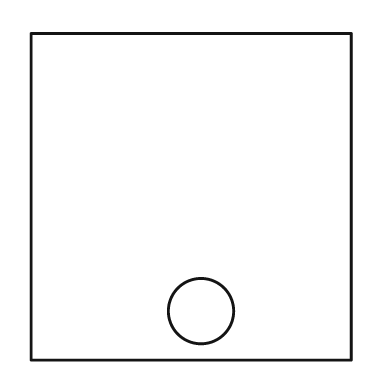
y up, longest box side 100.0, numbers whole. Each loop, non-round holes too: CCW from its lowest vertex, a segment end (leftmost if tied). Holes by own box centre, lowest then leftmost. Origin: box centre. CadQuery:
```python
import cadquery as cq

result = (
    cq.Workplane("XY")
    .moveTo(-49.0, -50.0)
    .lineTo(49.0, -50.0)
    .lineTo(49.0, 50.0)
    .lineTo(-49.0, 50.0)
    .close()
    .moveTo(3.0, -35.0)
    .circle(10.0)
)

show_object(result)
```